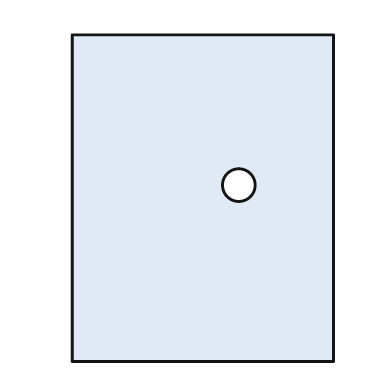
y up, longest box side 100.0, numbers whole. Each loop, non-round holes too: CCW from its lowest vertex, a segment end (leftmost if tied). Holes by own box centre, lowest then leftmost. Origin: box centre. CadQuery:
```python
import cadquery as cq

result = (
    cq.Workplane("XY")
    .moveTo(-40.0, -50.0)
    .lineTo(40.0, -50.0)
    .lineTo(40.0, 50.0)
    .lineTo(-40.0, 50.0)
    .close()
    .moveTo(11.0, 4.0)
    .circle(5.0)
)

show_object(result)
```